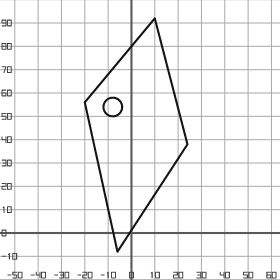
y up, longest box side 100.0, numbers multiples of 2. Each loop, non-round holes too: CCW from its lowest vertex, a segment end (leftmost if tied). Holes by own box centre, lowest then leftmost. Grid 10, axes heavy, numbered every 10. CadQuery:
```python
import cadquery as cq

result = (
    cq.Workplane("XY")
    .moveTo(-6.0, -8.0)
    .lineTo(24.0, 38.0)
    .lineTo(10.0, 92.0)
    .lineTo(-20.0, 56.0)
    .close()
    .moveTo(-8.0, 54.0)
    .circle(4.0)
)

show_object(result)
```